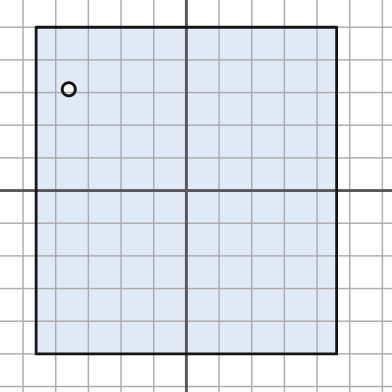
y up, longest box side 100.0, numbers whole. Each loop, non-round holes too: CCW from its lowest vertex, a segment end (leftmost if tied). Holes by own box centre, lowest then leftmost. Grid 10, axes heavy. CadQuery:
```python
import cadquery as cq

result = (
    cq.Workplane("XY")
    .moveTo(-46.0, -50.0)
    .lineTo(46.0, -50.0)
    .lineTo(46.0, 50.0)
    .lineTo(-46.0, 50.0)
    .close()
    .moveTo(-36.0, 31.0)
    .circle(2.0)
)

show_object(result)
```